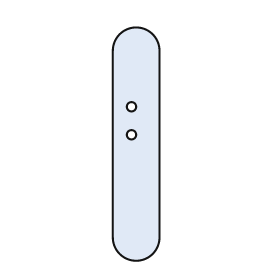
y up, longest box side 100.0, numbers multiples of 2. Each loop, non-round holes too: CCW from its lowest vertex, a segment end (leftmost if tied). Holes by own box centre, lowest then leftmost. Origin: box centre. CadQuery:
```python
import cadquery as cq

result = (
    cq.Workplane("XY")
    .moveTo(-10.0, -40.0)
    .threePointArc((0.0, -50.0), (10.0, -40.0))
    .lineTo(10.0, 40.0)
    .threePointArc((0.0, 50.0), (-10.0, 40.0))
    .close()
    .moveTo(-2.0, 4.0)
    .circle(2.0)
    .moveTo(-2.0, 16.0)
    .circle(2.0)
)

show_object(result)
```